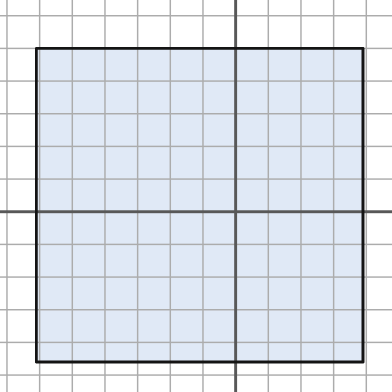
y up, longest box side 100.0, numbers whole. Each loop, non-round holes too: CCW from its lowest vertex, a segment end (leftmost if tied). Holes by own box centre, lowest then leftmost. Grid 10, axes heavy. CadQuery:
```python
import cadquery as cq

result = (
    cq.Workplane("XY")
    .moveTo(-61.0, -46.0)
    .lineTo(39.0, -46.0)
    .lineTo(39.0, 50.0)
    .lineTo(-61.0, 50.0)
    .close()
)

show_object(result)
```